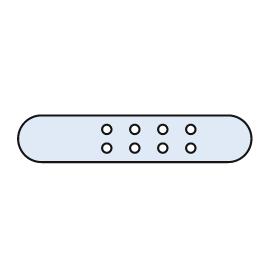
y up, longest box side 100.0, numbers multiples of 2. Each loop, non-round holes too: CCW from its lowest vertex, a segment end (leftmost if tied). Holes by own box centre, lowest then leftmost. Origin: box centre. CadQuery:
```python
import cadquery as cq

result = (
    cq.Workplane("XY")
    .moveTo(-40.0, -10.0)
    .lineTo(40.0, -10.0)
    .threePointArc((50.0, 0.0), (40.0, 10.0))
    .lineTo(-40.0, 10.0)
    .threePointArc((-50.0, 0.0), (-40.0, -10.0))
    .close()
    .moveTo(-12.0, -4.0)
    .circle(2.0)
    .moveTo(0.0, -4.0)
    .circle(2.0)
    .moveTo(12.0, -4.0)
    .circle(2.0)
    .moveTo(24.0, -4.0)
    .circle(2.0)
    .moveTo(-12.0, 4.0)
    .circle(2.0)
    .moveTo(0.0, 4.0)
    .circle(2.0)
    .moveTo(12.0, 4.0)
    .circle(2.0)
    .moveTo(24.0, 4.0)
    .circle(2.0)
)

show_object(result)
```